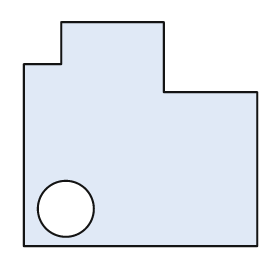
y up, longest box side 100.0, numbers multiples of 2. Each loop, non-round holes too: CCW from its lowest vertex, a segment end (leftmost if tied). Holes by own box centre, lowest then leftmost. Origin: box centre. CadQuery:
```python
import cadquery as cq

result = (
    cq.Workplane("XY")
    .moveTo(-50.0, -48.0)
    .lineTo(50.0, -48.0)
    .lineTo(50.0, 18.0)
    .lineTo(10.0, 18.0)
    .lineTo(10.0, 48.0)
    .lineTo(-34.0, 48.0)
    .lineTo(-34.0, 30.0)
    .lineTo(-50.0, 30.0)
    .close()
    .moveTo(-32.0, -32.0)
    .circle(12.0)
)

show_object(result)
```